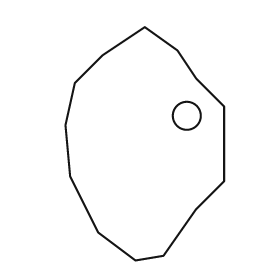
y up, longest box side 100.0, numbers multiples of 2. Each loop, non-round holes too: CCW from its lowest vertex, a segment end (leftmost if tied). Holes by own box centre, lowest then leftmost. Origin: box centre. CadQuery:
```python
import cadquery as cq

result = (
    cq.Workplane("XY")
    .moveTo(-4.0, -50.0)
    .lineTo(8.0, -48.0)
    .lineTo(22.0, -28.0)
    .lineTo(34.0, -16.0)
    .lineTo(34.0, 16.0)
    .lineTo(22.0, 28.0)
    .lineTo(14.0, 40.0)
    .lineTo(0.0, 50.0)
    .lineTo(-18.0, 38.0)
    .lineTo(-30.0, 26.0)
    .lineTo(-34.0, 8.0)
    .lineTo(-32.0, -14.0)
    .lineTo(-20.0, -38.0)
    .close()
    .moveTo(18.0, 12.0)
    .circle(6.0)
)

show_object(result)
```